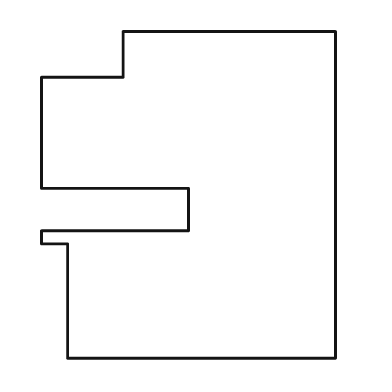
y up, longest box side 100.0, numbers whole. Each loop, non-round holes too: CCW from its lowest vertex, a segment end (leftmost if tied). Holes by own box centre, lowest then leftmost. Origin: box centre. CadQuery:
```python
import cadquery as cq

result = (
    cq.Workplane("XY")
    .moveTo(-37.0, -50.0)
    .lineTo(45.0, -50.0)
    .lineTo(45.0, 50.0)
    .lineTo(-20.0, 50.0)
    .lineTo(-20.0, 36.0)
    .lineTo(-45.0, 36.0)
    .lineTo(-45.0, 2.0)
    .lineTo(0.0, 2.0)
    .lineTo(0.0, -11.0)
    .lineTo(-45.0, -11.0)
    .lineTo(-45.0, -15.0)
    .lineTo(-37.0, -15.0)
    .close()
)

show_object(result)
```